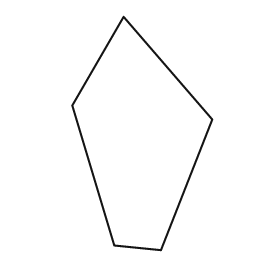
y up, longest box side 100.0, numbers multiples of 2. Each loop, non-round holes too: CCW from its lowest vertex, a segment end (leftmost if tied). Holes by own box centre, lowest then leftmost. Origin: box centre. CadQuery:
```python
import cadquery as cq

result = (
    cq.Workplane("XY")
    .moveTo(8.0, -50.0)
    .lineTo(30.0, 6.0)
    .lineTo(-8.0, 50.0)
    .lineTo(-30.0, 12.0)
    .lineTo(-12.0, -48.0)
    .close()
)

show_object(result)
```